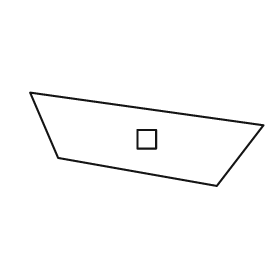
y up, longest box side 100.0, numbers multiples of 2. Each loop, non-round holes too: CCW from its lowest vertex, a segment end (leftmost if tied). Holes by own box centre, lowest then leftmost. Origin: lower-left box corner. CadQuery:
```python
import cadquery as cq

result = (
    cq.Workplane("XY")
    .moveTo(80.0, 0.0)
    .lineTo(100.0, 26.0)
    .lineTo(0.0, 40.0)
    .lineTo(12.0, 12.0)
    .close()
    .moveTo(46.0, 16.0)
    .lineTo(54.0, 16.0)
    .lineTo(54.0, 24.0)
    .lineTo(46.0, 24.0)
    .close()
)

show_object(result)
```